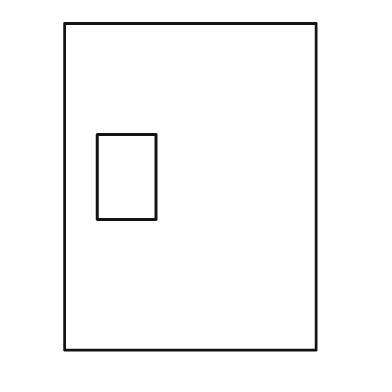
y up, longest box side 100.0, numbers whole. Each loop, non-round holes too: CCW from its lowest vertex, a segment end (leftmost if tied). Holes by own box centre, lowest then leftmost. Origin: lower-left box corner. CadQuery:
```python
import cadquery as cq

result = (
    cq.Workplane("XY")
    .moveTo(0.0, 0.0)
    .lineTo(77.0, 0.0)
    .lineTo(77.0, 100.0)
    .lineTo(0.0, 100.0)
    .close()
    .moveTo(10.0, 40.0)
    .lineTo(28.0, 40.0)
    .lineTo(28.0, 66.0)
    .lineTo(10.0, 66.0)
    .close()
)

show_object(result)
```